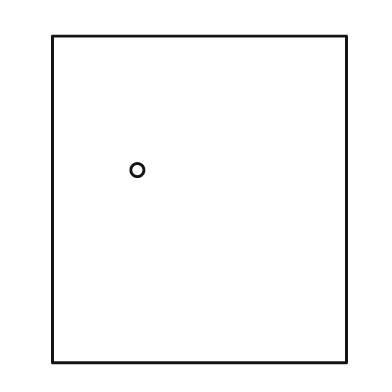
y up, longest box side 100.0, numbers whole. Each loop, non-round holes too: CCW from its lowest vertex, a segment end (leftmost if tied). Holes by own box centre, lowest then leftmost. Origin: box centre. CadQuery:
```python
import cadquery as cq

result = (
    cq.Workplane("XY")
    .moveTo(-45.0, -50.0)
    .lineTo(45.0, -50.0)
    .lineTo(45.0, 50.0)
    .lineTo(-45.0, 50.0)
    .close()
    .moveTo(-19.0, 9.0)
    .circle(2.0)
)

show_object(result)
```